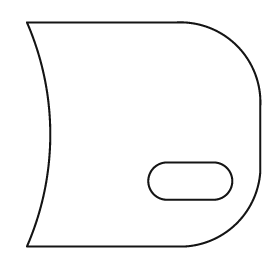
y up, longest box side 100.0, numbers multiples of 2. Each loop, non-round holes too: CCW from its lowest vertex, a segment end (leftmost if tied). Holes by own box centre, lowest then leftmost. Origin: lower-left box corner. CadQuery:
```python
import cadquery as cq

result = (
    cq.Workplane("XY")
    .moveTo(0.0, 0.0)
    .lineTo(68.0, 0.0)
    .threePointArc((90.0, 10.0), (100.0, 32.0))
    .lineTo(100.0, 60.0)
    .threePointArc((90.0, 86.0), (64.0, 96.0))
    .lineTo(0.0, 96.0)
    .threePointArc((10.0, 48.0), (0.0, 0.0))
    .close()
    .moveTo(60.0, 20.0)
    .lineTo(80.0, 20.0)
    .threePointArc((88.0, 28.0), (80.0, 36.0))
    .lineTo(60.0, 36.0)
    .threePointArc((52.0, 28.0), (60.0, 20.0))
    .close()
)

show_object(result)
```